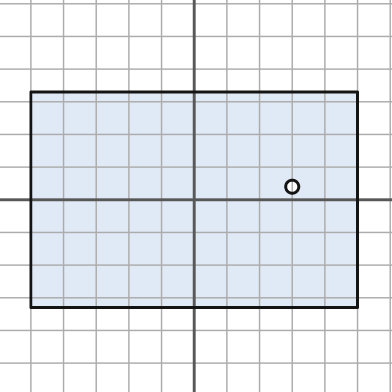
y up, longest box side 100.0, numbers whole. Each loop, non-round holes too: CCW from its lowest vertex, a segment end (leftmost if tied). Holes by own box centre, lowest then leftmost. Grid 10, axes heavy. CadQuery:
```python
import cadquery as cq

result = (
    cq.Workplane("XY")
    .moveTo(-50.0, -33.0)
    .lineTo(50.0, -33.0)
    .lineTo(50.0, 33.0)
    .lineTo(-50.0, 33.0)
    .close()
    .moveTo(30.0, 4.0)
    .circle(2.0)
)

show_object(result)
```